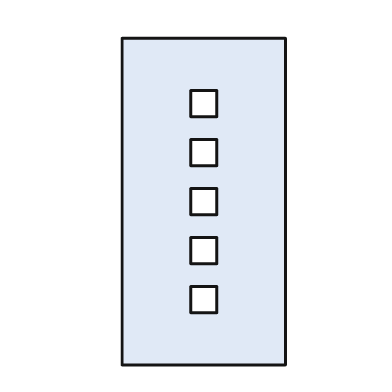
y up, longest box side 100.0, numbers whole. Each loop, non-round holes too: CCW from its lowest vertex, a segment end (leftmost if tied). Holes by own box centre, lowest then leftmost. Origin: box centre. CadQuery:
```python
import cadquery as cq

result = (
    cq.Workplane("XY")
    .moveTo(-25.0, -50.0)
    .lineTo(25.0, -50.0)
    .lineTo(25.0, 50.0)
    .lineTo(-25.0, 50.0)
    .close()
    .moveTo(-4.0, -34.0)
    .lineTo(4.0, -34.0)
    .lineTo(4.0, -26.0)
    .lineTo(-4.0, -26.0)
    .close()
    .moveTo(-4.0, -19.0)
    .lineTo(4.0, -19.0)
    .lineTo(4.0, -11.0)
    .lineTo(-4.0, -11.0)
    .close()
    .moveTo(-4.0, -4.0)
    .lineTo(4.0, -4.0)
    .lineTo(4.0, 4.0)
    .lineTo(-4.0, 4.0)
    .close()
    .moveTo(-4.0, 11.0)
    .lineTo(4.0, 11.0)
    .lineTo(4.0, 19.0)
    .lineTo(-4.0, 19.0)
    .close()
    .moveTo(-4.0, 26.0)
    .lineTo(4.0, 26.0)
    .lineTo(4.0, 34.0)
    .lineTo(-4.0, 34.0)
    .close()
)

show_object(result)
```